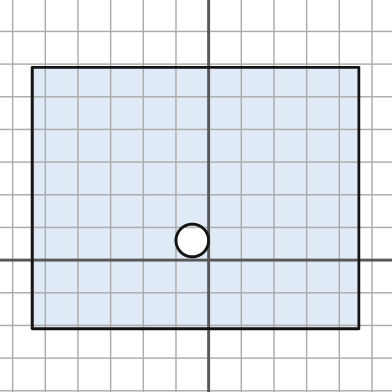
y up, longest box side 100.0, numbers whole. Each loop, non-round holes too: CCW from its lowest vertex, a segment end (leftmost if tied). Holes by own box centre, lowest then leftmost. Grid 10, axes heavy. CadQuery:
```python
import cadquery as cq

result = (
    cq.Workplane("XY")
    .moveTo(-54.0, -21.0)
    .lineTo(46.0, -21.0)
    .lineTo(46.0, 59.0)
    .lineTo(-54.0, 59.0)
    .close()
    .moveTo(-5.0, 6.0)
    .circle(5.0)
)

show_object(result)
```